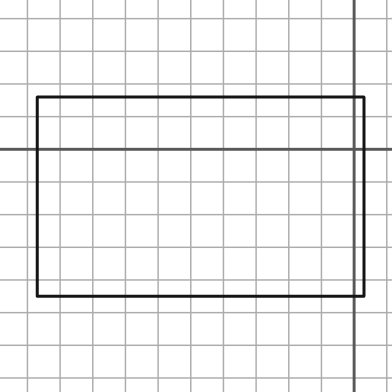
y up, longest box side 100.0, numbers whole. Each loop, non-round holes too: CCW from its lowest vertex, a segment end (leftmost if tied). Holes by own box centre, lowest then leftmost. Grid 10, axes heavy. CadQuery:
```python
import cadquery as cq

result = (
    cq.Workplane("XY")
    .moveTo(-97.0, -45.0)
    .lineTo(3.0, -45.0)
    .lineTo(3.0, 16.0)
    .lineTo(-97.0, 16.0)
    .close()
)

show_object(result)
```